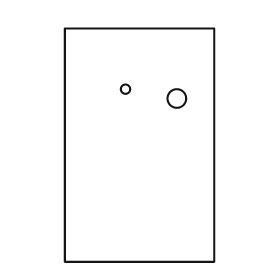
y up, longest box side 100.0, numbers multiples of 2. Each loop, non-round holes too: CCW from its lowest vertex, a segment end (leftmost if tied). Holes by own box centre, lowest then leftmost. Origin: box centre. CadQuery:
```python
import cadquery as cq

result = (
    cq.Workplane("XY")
    .moveTo(-32.0, -50.0)
    .lineTo(32.0, -50.0)
    .lineTo(32.0, 50.0)
    .lineTo(-32.0, 50.0)
    .close()
    .moveTo(16.0, 20.0)
    .circle(4.0)
    .moveTo(-6.0, 24.0)
    .circle(2.0)
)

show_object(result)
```